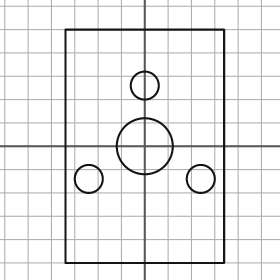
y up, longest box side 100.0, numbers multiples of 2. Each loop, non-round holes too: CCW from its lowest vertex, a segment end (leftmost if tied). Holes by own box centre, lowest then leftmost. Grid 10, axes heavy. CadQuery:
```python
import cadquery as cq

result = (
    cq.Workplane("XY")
    .moveTo(-34.0, -50.0)
    .lineTo(34.0, -50.0)
    .lineTo(34.0, 50.0)
    .lineTo(-34.0, 50.0)
    .close()
    .moveTo(-24.0, -14.0)
    .circle(6.0)
    .moveTo(24.0, -14.0)
    .circle(6.0)
    .moveTo(0.0, 0.0)
    .circle(12.0)
    .moveTo(0.0, 26.0)
    .circle(6.0)
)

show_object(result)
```